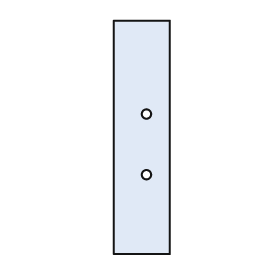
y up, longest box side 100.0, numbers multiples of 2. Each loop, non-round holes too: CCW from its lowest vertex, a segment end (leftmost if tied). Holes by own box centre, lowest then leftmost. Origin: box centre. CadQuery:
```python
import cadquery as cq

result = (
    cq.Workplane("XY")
    .moveTo(-12.0, -50.0)
    .lineTo(12.0, -50.0)
    .lineTo(12.0, 50.0)
    .lineTo(-12.0, 50.0)
    .close()
    .moveTo(2.0, -16.0)
    .circle(2.0)
    .moveTo(2.0, 10.0)
    .circle(2.0)
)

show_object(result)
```